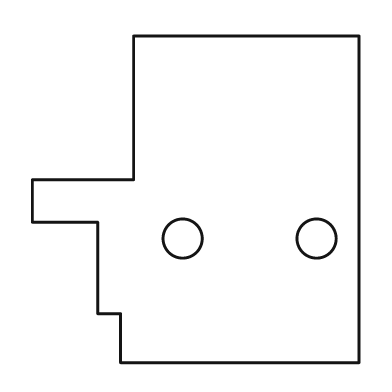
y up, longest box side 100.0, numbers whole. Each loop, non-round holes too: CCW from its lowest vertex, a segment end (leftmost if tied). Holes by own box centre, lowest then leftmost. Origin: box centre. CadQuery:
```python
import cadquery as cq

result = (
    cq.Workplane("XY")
    .moveTo(-23.0, -50.0)
    .lineTo(50.0, -50.0)
    .lineTo(50.0, 50.0)
    .lineTo(-19.0, 50.0)
    .lineTo(-19.0, 6.0)
    .lineTo(-50.0, 6.0)
    .lineTo(-50.0, -7.0)
    .lineTo(-30.0, -7.0)
    .lineTo(-30.0, -35.0)
    .lineTo(-23.0, -35.0)
    .close()
    .moveTo(-4.0, -12.0)
    .circle(6.0)
    .moveTo(37.0, -12.0)
    .circle(6.0)
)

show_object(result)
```